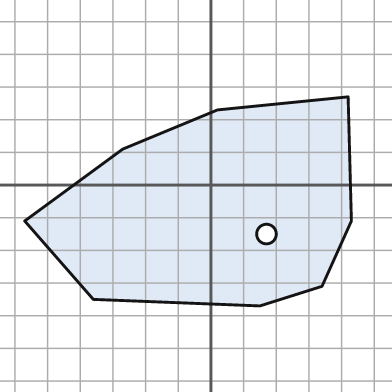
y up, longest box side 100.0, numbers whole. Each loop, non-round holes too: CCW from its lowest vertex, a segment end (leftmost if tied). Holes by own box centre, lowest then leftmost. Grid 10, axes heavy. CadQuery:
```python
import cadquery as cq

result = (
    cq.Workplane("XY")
    .moveTo(15.0, -37.0)
    .lineTo(34.0, -31.0)
    .lineTo(43.0, -11.0)
    .lineTo(42.0, 27.0)
    .lineTo(2.0, 23.0)
    .lineTo(-27.0, 11.0)
    .lineTo(-57.0, -11.0)
    .lineTo(-36.0, -35.0)
    .close()
    .moveTo(17.0, -15.0)
    .circle(3.0)
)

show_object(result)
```